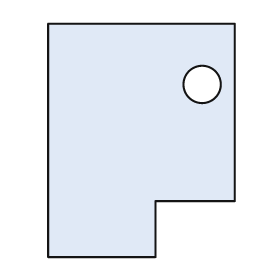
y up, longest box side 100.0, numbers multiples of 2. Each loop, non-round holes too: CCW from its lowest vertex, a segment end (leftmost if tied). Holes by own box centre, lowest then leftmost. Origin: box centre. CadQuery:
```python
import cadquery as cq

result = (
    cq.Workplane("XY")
    .moveTo(-40.0, -50.0)
    .lineTo(6.0, -50.0)
    .lineTo(6.0, -26.0)
    .lineTo(40.0, -26.0)
    .lineTo(40.0, 50.0)
    .lineTo(-40.0, 50.0)
    .close()
    .moveTo(26.0, 24.0)
    .circle(8.0)
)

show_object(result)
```